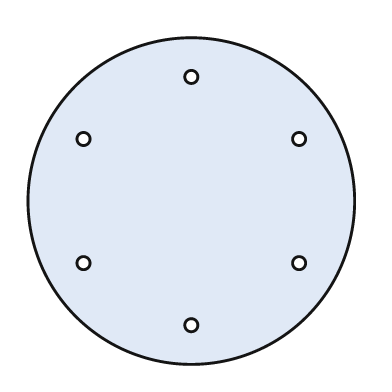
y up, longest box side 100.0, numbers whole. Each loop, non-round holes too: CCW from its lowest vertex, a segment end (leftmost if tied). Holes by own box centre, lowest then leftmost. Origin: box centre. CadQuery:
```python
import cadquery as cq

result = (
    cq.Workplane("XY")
    .moveTo(0.0, 0.0)
    .circle(50.0)
    .moveTo(0.0, -38.0)
    .circle(2.0)
    .moveTo(-33.0, -19.0)
    .circle(2.0)
    .moveTo(33.0, -19.0)
    .circle(2.0)
    .moveTo(-33.0, 19.0)
    .circle(2.0)
    .moveTo(33.0, 19.0)
    .circle(2.0)
    .moveTo(0.0, 38.0)
    .circle(2.0)
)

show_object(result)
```